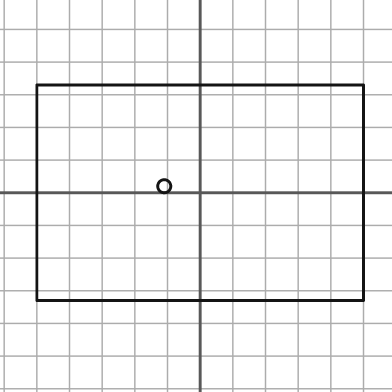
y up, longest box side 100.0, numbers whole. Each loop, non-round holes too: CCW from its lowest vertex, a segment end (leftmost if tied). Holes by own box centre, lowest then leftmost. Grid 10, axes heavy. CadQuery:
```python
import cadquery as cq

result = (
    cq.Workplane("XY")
    .moveTo(-50.0, -33.0)
    .lineTo(50.0, -33.0)
    .lineTo(50.0, 33.0)
    .lineTo(-50.0, 33.0)
    .close()
    .moveTo(-11.0, 2.0)
    .circle(2.0)
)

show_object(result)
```